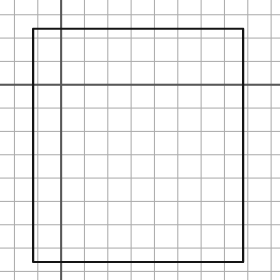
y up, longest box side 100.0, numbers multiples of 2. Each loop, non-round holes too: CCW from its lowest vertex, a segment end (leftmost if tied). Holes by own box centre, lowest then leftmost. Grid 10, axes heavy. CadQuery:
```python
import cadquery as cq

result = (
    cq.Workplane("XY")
    .moveTo(-12.0, -76.0)
    .lineTo(78.0, -76.0)
    .lineTo(78.0, 24.0)
    .lineTo(-12.0, 24.0)
    .close()
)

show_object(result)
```